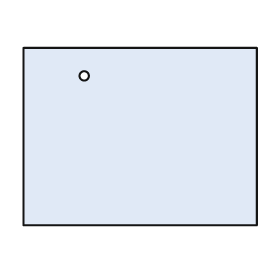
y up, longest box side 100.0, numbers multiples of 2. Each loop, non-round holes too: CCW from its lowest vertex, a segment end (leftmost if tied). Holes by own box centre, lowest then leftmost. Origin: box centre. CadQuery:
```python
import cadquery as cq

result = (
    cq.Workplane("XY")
    .moveTo(-50.0, -38.0)
    .lineTo(50.0, -38.0)
    .lineTo(50.0, 38.0)
    .lineTo(-50.0, 38.0)
    .close()
    .moveTo(-24.0, 26.0)
    .circle(2.0)
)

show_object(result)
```